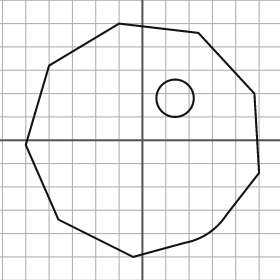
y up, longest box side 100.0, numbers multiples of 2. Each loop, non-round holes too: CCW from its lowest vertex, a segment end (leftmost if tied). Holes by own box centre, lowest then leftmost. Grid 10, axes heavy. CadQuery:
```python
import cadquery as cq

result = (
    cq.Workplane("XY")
    .moveTo(-4.0, -50.0)
    .lineTo(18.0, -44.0)
    .threePointArc((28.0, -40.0), (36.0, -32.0))
    .lineTo(50.0, -14.0)
    .lineTo(48.0, 20.0)
    .lineTo(24.0, 46.0)
    .lineTo(-10.0, 50.0)
    .lineTo(-40.0, 32.0)
    .lineTo(-50.0, -2.0)
    .lineTo(-36.0, -34.0)
    .close()
    .moveTo(14.0, 18.0)
    .circle(8.0)
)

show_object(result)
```